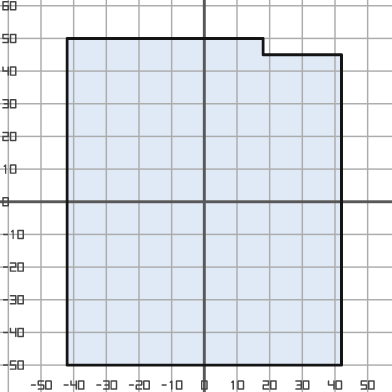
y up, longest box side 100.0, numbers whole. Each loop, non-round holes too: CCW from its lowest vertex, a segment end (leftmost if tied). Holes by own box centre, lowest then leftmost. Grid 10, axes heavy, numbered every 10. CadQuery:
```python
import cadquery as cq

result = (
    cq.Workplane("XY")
    .moveTo(-42.0, -50.0)
    .lineTo(42.0, -50.0)
    .lineTo(42.0, 45.0)
    .lineTo(18.0, 45.0)
    .lineTo(18.0, 50.0)
    .lineTo(-42.0, 50.0)
    .close()
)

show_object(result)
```